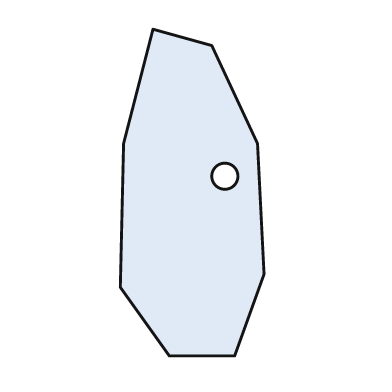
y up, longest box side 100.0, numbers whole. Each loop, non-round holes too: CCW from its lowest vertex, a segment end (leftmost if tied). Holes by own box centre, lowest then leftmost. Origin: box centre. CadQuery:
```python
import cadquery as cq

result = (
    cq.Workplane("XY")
    .moveTo(-7.0, -50.0)
    .lineTo(13.0, -50.0)
    .lineTo(22.0, -25.0)
    .lineTo(20.0, 15.0)
    .lineTo(6.0, 45.0)
    .lineTo(-12.0, 50.0)
    .lineTo(-21.0, 15.0)
    .lineTo(-22.0, -29.0)
    .close()
    .moveTo(10.0, 5.0)
    .circle(4.0)
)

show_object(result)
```